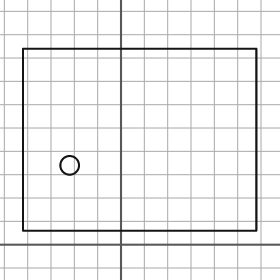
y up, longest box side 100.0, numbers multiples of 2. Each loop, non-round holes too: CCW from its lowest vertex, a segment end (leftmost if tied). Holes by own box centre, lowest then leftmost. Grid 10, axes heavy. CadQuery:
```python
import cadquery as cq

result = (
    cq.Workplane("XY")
    .moveTo(-42.0, 6.0)
    .lineTo(58.0, 6.0)
    .lineTo(58.0, 84.0)
    .lineTo(-42.0, 84.0)
    .close()
    .moveTo(-22.0, 34.0)
    .circle(4.0)
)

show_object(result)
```